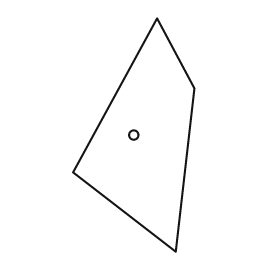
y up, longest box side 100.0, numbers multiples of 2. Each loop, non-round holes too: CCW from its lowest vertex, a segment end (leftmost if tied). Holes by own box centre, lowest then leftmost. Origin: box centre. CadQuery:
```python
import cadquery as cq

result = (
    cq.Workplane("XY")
    .moveTo(18.0, -50.0)
    .lineTo(26.0, 20.0)
    .lineTo(10.0, 50.0)
    .lineTo(-26.0, -16.0)
    .close()
    .moveTo(0.0, 0.0)
    .circle(2.0)
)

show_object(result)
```